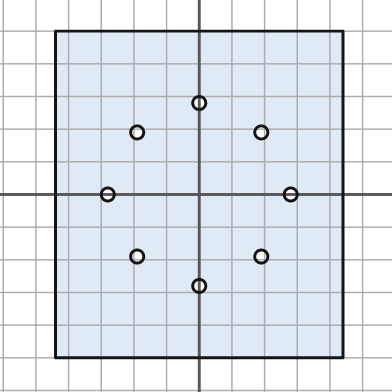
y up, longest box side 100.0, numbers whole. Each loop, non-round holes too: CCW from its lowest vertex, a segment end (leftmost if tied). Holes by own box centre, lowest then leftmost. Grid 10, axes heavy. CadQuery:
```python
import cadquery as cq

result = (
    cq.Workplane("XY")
    .moveTo(-44.0, -50.0)
    .lineTo(44.0, -50.0)
    .lineTo(44.0, 50.0)
    .lineTo(-44.0, 50.0)
    .close()
    .moveTo(0.0, -28.0)
    .circle(2.0)
    .moveTo(-19.0, -19.0)
    .circle(2.0)
    .moveTo(19.0, -19.0)
    .circle(2.0)
    .moveTo(-28.0, 0.0)
    .circle(2.0)
    .moveTo(28.0, 0.0)
    .circle(2.0)
    .moveTo(-19.0, 19.0)
    .circle(2.0)
    .moveTo(19.0, 19.0)
    .circle(2.0)
    .moveTo(0.0, 28.0)
    .circle(2.0)
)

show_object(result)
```